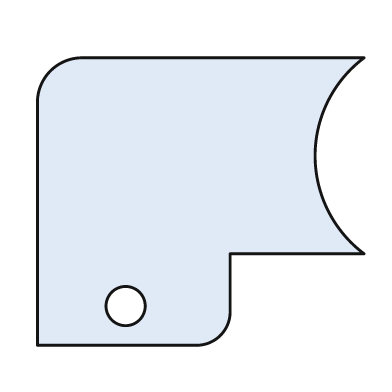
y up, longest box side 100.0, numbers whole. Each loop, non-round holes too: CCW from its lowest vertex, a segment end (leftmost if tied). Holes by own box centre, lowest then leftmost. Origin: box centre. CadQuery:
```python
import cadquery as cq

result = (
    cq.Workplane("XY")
    .moveTo(-50.0, -44.0)
    .lineTo(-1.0, -44.0)
    .threePointArc((6.0, -41.0), (9.0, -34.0))
    .lineTo(9.0, -16.0)
    .lineTo(50.0, -16.0)
    .threePointArc((35.0, 14.0), (50.0, 44.0))
    .lineTo(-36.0, 44.0)
    .threePointArc((-46.0, 40.0), (-50.0, 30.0))
    .close()
    .moveTo(-23.0, -32.0)
    .circle(6.0)
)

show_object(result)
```